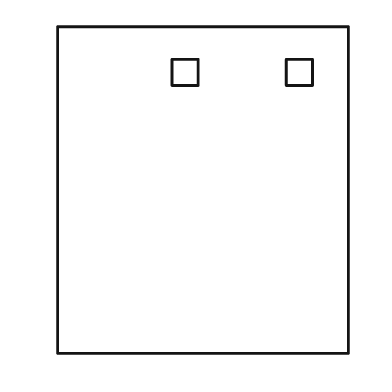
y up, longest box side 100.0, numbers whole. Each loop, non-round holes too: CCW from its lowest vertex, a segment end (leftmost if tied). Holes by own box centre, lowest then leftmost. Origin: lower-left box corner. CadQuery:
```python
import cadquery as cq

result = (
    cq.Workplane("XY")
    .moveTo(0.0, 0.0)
    .lineTo(89.0, 0.0)
    .lineTo(89.0, 100.0)
    .lineTo(0.0, 100.0)
    .close()
    .moveTo(35.0, 82.0)
    .lineTo(43.0, 82.0)
    .lineTo(43.0, 90.0)
    .lineTo(35.0, 90.0)
    .close()
    .moveTo(70.0, 82.0)
    .lineTo(78.0, 82.0)
    .lineTo(78.0, 90.0)
    .lineTo(70.0, 90.0)
    .close()
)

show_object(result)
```